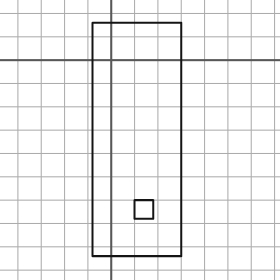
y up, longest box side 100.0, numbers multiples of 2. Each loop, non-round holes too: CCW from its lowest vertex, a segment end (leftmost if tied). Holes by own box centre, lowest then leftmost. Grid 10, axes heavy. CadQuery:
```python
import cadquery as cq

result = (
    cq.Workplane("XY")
    .moveTo(-8.0, -84.0)
    .lineTo(30.0, -84.0)
    .lineTo(30.0, 16.0)
    .lineTo(-8.0, 16.0)
    .close()
    .moveTo(10.0, -68.0)
    .lineTo(18.0, -68.0)
    .lineTo(18.0, -60.0)
    .lineTo(10.0, -60.0)
    .close()
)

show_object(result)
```